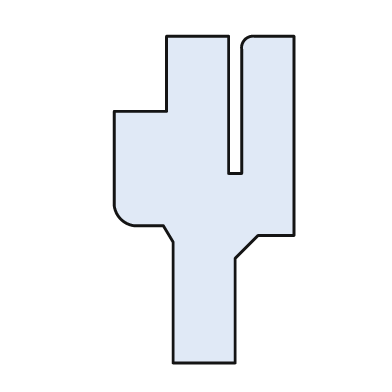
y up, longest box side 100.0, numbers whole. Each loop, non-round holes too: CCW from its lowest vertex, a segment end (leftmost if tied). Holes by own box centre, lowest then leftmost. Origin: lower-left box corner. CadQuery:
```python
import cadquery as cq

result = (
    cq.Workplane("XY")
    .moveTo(18.0, 0.0)
    .lineTo(37.0, 0.0)
    .lineTo(37.0, 32.0)
    .lineTo(44.0, 39.0)
    .lineTo(55.0, 39.0)
    .lineTo(55.0, 100.0)
    .lineTo(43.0, 100.0)
    .threePointArc((40.0, 99.0), (39.0, 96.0))
    .lineTo(39.0, 58.0)
    .lineTo(35.0, 58.0)
    .lineTo(35.0, 100.0)
    .lineTo(16.0, 100.0)
    .lineTo(16.0, 77.0)
    .lineTo(0.0, 77.0)
    .lineTo(0.0, 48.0)
    .threePointArc((2.0, 44.0), (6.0, 42.0))
    .lineTo(15.0, 42.0)
    .lineTo(18.0, 37.0)
    .close()
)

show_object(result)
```